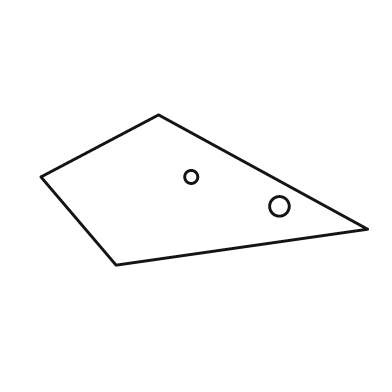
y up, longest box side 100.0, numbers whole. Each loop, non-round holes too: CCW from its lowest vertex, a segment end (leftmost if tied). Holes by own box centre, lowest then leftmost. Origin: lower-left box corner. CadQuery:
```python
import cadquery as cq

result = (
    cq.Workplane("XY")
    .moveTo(23.0, 0.0)
    .lineTo(100.0, 11.0)
    .lineTo(36.0, 46.0)
    .lineTo(0.0, 27.0)
    .close()
    .moveTo(73.0, 18.0)
    .circle(3.0)
    .moveTo(46.0, 27.0)
    .circle(2.0)
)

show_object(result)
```